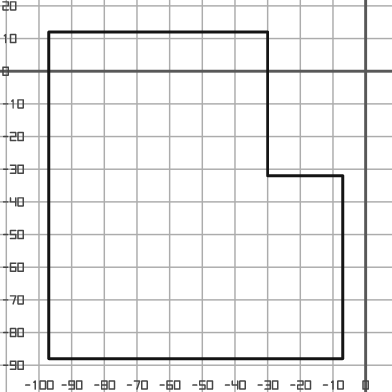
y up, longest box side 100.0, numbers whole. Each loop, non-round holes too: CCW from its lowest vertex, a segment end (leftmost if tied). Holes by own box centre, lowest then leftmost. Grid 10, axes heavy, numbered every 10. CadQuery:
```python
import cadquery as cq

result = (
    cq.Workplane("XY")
    .moveTo(-97.0, -88.0)
    .lineTo(-7.0, -88.0)
    .lineTo(-7.0, -32.0)
    .lineTo(-30.0, -32.0)
    .lineTo(-30.0, 12.0)
    .lineTo(-97.0, 12.0)
    .close()
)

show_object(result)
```